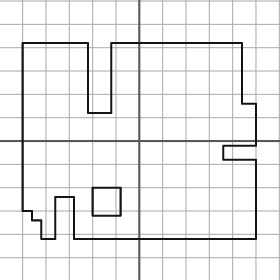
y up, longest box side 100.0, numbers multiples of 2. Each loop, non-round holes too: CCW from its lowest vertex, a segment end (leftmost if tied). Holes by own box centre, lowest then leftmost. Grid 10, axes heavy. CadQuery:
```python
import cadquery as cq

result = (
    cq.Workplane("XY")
    .moveTo(-42.0, -42.0)
    .lineTo(-36.0, -42.0)
    .lineTo(-36.0, -24.0)
    .lineTo(-28.0, -24.0)
    .lineTo(-28.0, -42.0)
    .lineTo(50.0, -42.0)
    .lineTo(50.0, -8.0)
    .lineTo(36.0, -8.0)
    .lineTo(36.0, -2.0)
    .lineTo(50.0, -2.0)
    .lineTo(50.0, 16.0)
    .lineTo(44.0, 16.0)
    .lineTo(44.0, 42.0)
    .lineTo(-12.0, 42.0)
    .lineTo(-12.0, 12.0)
    .lineTo(-22.0, 12.0)
    .lineTo(-22.0, 42.0)
    .lineTo(-50.0, 42.0)
    .lineTo(-50.0, -30.0)
    .lineTo(-46.0, -30.0)
    .lineTo(-46.0, -34.0)
    .lineTo(-42.0, -34.0)
    .close()
    .moveTo(-20.0, -32.0)
    .lineTo(-8.0, -32.0)
    .lineTo(-8.0, -20.0)
    .lineTo(-20.0, -20.0)
    .close()
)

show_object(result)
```